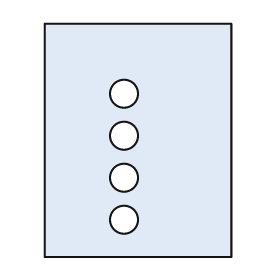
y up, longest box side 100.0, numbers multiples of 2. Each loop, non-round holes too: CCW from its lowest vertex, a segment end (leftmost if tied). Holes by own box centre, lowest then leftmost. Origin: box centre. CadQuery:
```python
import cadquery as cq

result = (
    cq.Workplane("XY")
    .moveTo(-40.0, -50.0)
    .lineTo(40.0, -50.0)
    .lineTo(40.0, 50.0)
    .lineTo(-40.0, 50.0)
    .close()
    .moveTo(-6.0, -34.0)
    .circle(6.0)
    .moveTo(-6.0, -16.0)
    .circle(6.0)
    .moveTo(-6.0, 2.0)
    .circle(6.0)
    .moveTo(-6.0, 20.0)
    .circle(6.0)
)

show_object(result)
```